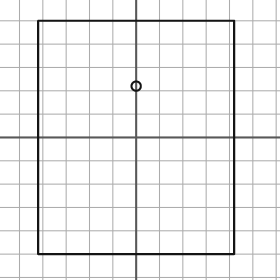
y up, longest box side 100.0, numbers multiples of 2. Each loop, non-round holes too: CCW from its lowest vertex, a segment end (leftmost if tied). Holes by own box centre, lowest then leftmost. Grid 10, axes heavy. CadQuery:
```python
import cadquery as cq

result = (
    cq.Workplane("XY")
    .moveTo(-42.0, -50.0)
    .lineTo(42.0, -50.0)
    .lineTo(42.0, 50.0)
    .lineTo(-42.0, 50.0)
    .close()
    .moveTo(0.0, 22.0)
    .circle(2.0)
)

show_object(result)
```